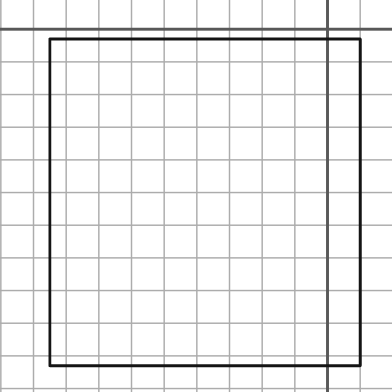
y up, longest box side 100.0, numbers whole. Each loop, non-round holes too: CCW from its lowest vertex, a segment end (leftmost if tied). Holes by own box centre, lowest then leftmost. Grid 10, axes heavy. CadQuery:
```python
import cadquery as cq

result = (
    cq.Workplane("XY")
    .moveTo(-85.0, -103.0)
    .lineTo(10.0, -103.0)
    .lineTo(10.0, -3.0)
    .lineTo(-85.0, -3.0)
    .close()
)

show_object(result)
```